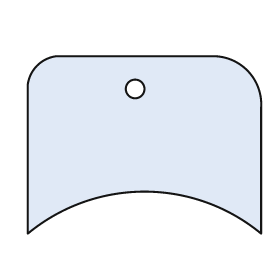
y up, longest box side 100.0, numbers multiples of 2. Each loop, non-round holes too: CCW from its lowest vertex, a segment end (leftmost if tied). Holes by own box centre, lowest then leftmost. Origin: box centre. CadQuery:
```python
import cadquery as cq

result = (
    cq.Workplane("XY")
    .moveTo(-50.0, -38.0)
    .threePointArc((0.0, -20.0), (50.0, -38.0))
    .lineTo(50.0, 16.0)
    .threePointArc((44.0, 32.0), (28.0, 38.0))
    .lineTo(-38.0, 38.0)
    .threePointArc((-46.0, 34.0), (-50.0, 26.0))
    .close()
    .moveTo(-4.0, 24.0)
    .circle(4.0)
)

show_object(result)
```